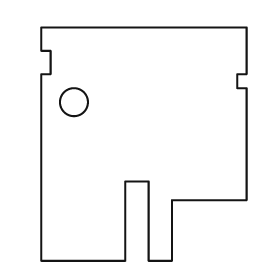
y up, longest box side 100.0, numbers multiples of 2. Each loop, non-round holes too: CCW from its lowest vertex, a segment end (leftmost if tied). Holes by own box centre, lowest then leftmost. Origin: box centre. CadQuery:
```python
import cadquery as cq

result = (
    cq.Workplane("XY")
    .moveTo(-44.0, -50.0)
    .lineTo(-8.0, -50.0)
    .lineTo(-8.0, -16.0)
    .lineTo(2.0, -16.0)
    .lineTo(2.0, -50.0)
    .lineTo(12.0, -50.0)
    .lineTo(12.0, -24.0)
    .lineTo(44.0, -24.0)
    .lineTo(44.0, 24.0)
    .lineTo(40.0, 24.0)
    .lineTo(40.0, 30.0)
    .lineTo(44.0, 30.0)
    .lineTo(44.0, 50.0)
    .lineTo(-44.0, 50.0)
    .lineTo(-44.0, 40.0)
    .lineTo(-40.0, 40.0)
    .lineTo(-40.0, 30.0)
    .lineTo(-44.0, 30.0)
    .close()
    .moveTo(-30.0, 18.0)
    .circle(6.0)
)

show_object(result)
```